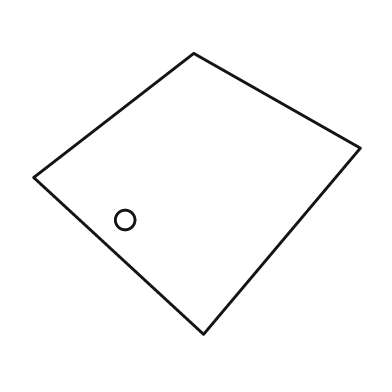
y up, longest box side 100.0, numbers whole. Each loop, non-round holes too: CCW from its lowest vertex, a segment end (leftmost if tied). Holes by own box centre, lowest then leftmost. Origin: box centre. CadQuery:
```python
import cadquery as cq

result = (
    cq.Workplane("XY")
    .moveTo(2.0, -43.0)
    .lineTo(50.0, 14.0)
    .lineTo(-1.0, 43.0)
    .lineTo(-50.0, 5.0)
    .close()
    .moveTo(-22.0, -8.0)
    .circle(3.0)
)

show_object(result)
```